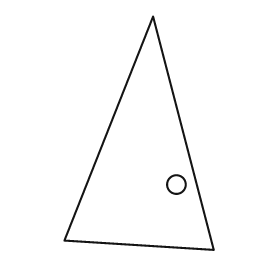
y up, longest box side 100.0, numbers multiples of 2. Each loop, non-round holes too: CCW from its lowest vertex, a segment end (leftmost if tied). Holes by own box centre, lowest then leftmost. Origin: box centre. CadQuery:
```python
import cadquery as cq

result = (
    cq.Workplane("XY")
    .moveTo(32.0, -50.0)
    .lineTo(6.0, 50.0)
    .lineTo(-32.0, -46.0)
    .close()
    .moveTo(16.0, -22.0)
    .circle(4.0)
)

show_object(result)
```